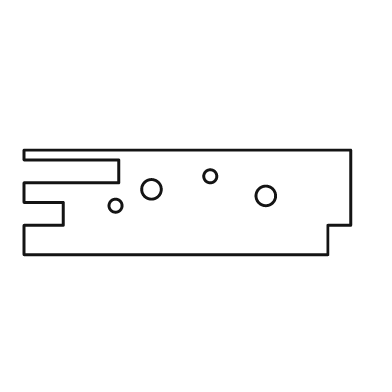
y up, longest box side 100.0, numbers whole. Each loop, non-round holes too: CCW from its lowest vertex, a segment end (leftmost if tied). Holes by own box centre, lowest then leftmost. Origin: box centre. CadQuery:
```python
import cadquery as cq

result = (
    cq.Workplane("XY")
    .moveTo(-50.0, -16.0)
    .lineTo(43.0, -16.0)
    .lineTo(43.0, -7.0)
    .lineTo(50.0, -7.0)
    .lineTo(50.0, 16.0)
    .lineTo(-50.0, 16.0)
    .lineTo(-50.0, 13.0)
    .lineTo(-21.0, 13.0)
    .lineTo(-21.0, 6.0)
    .lineTo(-50.0, 6.0)
    .lineTo(-50.0, 0.0)
    .lineTo(-38.0, 0.0)
    .lineTo(-38.0, -7.0)
    .lineTo(-50.0, -7.0)
    .close()
    .moveTo(-22.0, -1.0)
    .circle(2.0)
    .moveTo(24.0, 2.0)
    .circle(3.0)
    .moveTo(-11.0, 4.0)
    .circle(3.0)
    .moveTo(7.0, 8.0)
    .circle(2.0)
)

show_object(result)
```